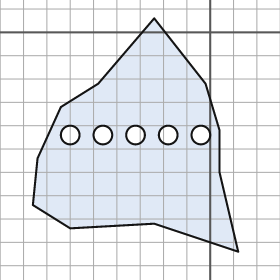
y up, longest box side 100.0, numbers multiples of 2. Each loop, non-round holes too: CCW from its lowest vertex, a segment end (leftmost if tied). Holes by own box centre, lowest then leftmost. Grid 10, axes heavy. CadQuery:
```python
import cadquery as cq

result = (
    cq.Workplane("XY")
    .moveTo(12.0, -94.0)
    .lineTo(4.0, -60.0)
    .lineTo(4.0, -42.0)
    .lineTo(-2.0, -22.0)
    .lineTo(-24.0, 6.0)
    .lineTo(-48.0, -22.0)
    .lineTo(-64.0, -32.0)
    .lineTo(-74.0, -54.0)
    .lineTo(-76.0, -74.0)
    .lineTo(-60.0, -84.0)
    .lineTo(-24.0, -82.0)
    .close()
    .moveTo(-60.0, -44.0)
    .circle(4.0)
    .moveTo(-46.0, -44.0)
    .circle(4.0)
    .moveTo(-32.0, -44.0)
    .circle(4.0)
    .moveTo(-18.0, -44.0)
    .circle(4.0)
    .moveTo(-4.0, -44.0)
    .circle(4.0)
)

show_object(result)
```